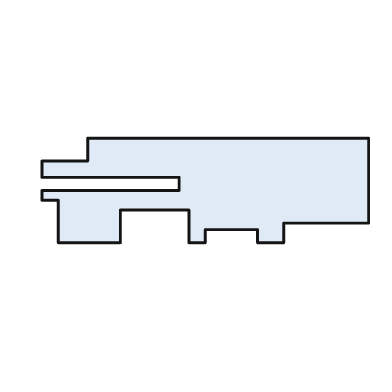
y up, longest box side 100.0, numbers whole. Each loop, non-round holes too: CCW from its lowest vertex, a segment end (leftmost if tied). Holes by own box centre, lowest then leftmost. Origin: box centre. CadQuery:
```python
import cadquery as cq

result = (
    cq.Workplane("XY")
    .moveTo(-45.0, -16.0)
    .lineTo(-26.0, -16.0)
    .lineTo(-26.0, -6.0)
    .lineTo(-5.0, -6.0)
    .lineTo(-5.0, -16.0)
    .lineTo(0.0, -16.0)
    .lineTo(0.0, -12.0)
    .lineTo(16.0, -12.0)
    .lineTo(16.0, -16.0)
    .lineTo(24.0, -16.0)
    .lineTo(24.0, -10.0)
    .lineTo(50.0, -10.0)
    .lineTo(50.0, 16.0)
    .lineTo(-36.0, 16.0)
    .lineTo(-36.0, 9.0)
    .lineTo(-50.0, 9.0)
    .lineTo(-50.0, 4.0)
    .lineTo(-8.0, 4.0)
    .lineTo(-8.0, 0.0)
    .lineTo(-50.0, 0.0)
    .lineTo(-50.0, -3.0)
    .lineTo(-45.0, -3.0)
    .close()
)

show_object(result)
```